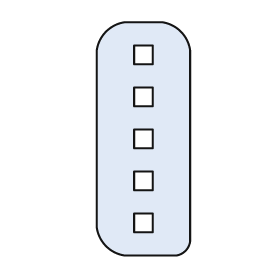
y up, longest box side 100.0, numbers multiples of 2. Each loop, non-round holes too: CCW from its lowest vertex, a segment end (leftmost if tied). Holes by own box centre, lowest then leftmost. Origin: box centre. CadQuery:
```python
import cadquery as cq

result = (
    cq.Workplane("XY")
    .moveTo(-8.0, -50.0)
    .lineTo(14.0, -50.0)
    .threePointArc((18.0, -48.0), (20.0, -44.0))
    .lineTo(20.0, 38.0)
    .threePointArc((16.0, 46.0), (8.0, 50.0))
    .lineTo(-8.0, 50.0)
    .threePointArc((-16.0, 46.0), (-20.0, 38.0))
    .lineTo(-20.0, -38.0)
    .threePointArc((-16.0, -46.0), (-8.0, -50.0))
    .close()
    .moveTo(-4.0, -40.0)
    .lineTo(4.0, -40.0)
    .lineTo(4.0, -32.0)
    .lineTo(-4.0, -32.0)
    .close()
    .moveTo(-4.0, -22.0)
    .lineTo(4.0, -22.0)
    .lineTo(4.0, -14.0)
    .lineTo(-4.0, -14.0)
    .close()
    .moveTo(-4.0, -4.0)
    .lineTo(4.0, -4.0)
    .lineTo(4.0, 4.0)
    .lineTo(-4.0, 4.0)
    .close()
    .moveTo(-4.0, 14.0)
    .lineTo(4.0, 14.0)
    .lineTo(4.0, 22.0)
    .lineTo(-4.0, 22.0)
    .close()
    .moveTo(-4.0, 32.0)
    .lineTo(4.0, 32.0)
    .lineTo(4.0, 40.0)
    .lineTo(-4.0, 40.0)
    .close()
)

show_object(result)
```